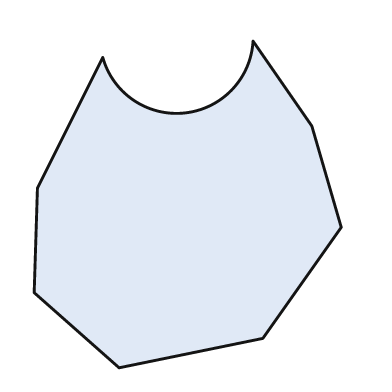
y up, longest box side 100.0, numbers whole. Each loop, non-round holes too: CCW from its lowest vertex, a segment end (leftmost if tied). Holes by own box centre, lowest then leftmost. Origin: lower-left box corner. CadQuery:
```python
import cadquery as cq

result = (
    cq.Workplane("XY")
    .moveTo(26.0, 0.0)
    .lineTo(70.0, 9.0)
    .lineTo(94.0, 43.0)
    .lineTo(85.0, 74.0)
    .lineTo(67.0, 100.0)
    .threePointArc((46.0, 78.0), (21.0, 95.0))
    .lineTo(1.0, 55.0)
    .lineTo(0.0, 23.0)
    .close()
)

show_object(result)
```